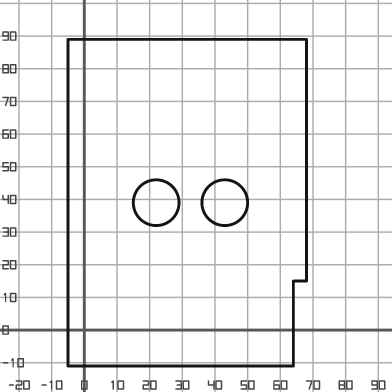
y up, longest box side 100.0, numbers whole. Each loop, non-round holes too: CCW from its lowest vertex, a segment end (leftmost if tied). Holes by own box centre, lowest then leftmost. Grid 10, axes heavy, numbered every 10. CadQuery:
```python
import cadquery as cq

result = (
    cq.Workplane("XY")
    .moveTo(-5.0, -11.0)
    .lineTo(64.0, -11.0)
    .lineTo(64.0, 15.0)
    .lineTo(68.0, 15.0)
    .lineTo(68.0, 89.0)
    .lineTo(-5.0, 89.0)
    .close()
    .moveTo(22.0, 39.0)
    .circle(7.0)
    .moveTo(43.0, 39.0)
    .circle(7.0)
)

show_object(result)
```